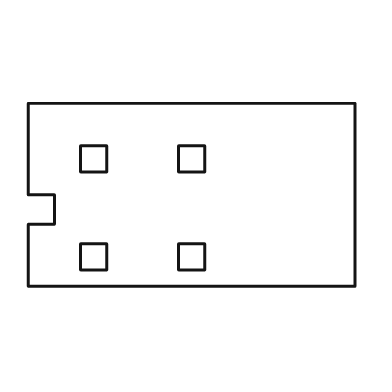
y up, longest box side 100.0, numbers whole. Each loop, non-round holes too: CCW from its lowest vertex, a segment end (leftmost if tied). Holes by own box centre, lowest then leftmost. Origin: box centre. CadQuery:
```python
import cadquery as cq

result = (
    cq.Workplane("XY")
    .moveTo(-50.0, -28.0)
    .lineTo(50.0, -28.0)
    .lineTo(50.0, 28.0)
    .lineTo(-50.0, 28.0)
    .lineTo(-50.0, 0.0)
    .lineTo(-42.0, 0.0)
    .lineTo(-42.0, -9.0)
    .lineTo(-50.0, -9.0)
    .close()
    .moveTo(-34.0, -23.0)
    .lineTo(-26.0, -23.0)
    .lineTo(-26.0, -15.0)
    .lineTo(-34.0, -15.0)
    .close()
    .moveTo(-4.0, -23.0)
    .lineTo(4.0, -23.0)
    .lineTo(4.0, -15.0)
    .lineTo(-4.0, -15.0)
    .close()
    .moveTo(-34.0, 7.0)
    .lineTo(-26.0, 7.0)
    .lineTo(-26.0, 15.0)
    .lineTo(-34.0, 15.0)
    .close()
    .moveTo(-4.0, 7.0)
    .lineTo(4.0, 7.0)
    .lineTo(4.0, 15.0)
    .lineTo(-4.0, 15.0)
    .close()
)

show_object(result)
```